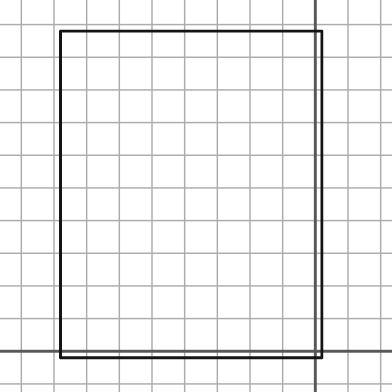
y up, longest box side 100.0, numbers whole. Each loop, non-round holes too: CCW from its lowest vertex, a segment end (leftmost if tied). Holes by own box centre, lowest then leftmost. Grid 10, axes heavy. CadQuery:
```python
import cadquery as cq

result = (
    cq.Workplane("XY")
    .moveTo(-78.0, -2.0)
    .lineTo(2.0, -2.0)
    .lineTo(2.0, 98.0)
    .lineTo(-78.0, 98.0)
    .close()
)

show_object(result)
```